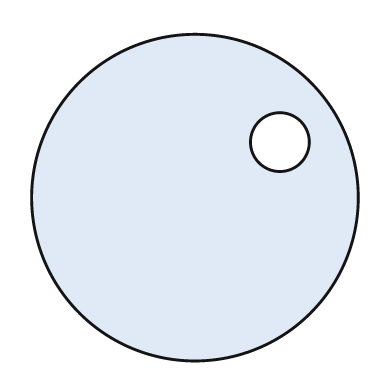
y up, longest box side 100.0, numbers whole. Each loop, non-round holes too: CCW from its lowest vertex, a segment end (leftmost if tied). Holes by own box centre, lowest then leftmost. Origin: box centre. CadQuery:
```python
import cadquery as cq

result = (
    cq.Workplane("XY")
    .moveTo(0.0, 0.0)
    .circle(50.0)
    .moveTo(26.0, 17.0)
    .circle(9.0)
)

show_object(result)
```